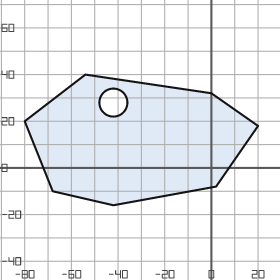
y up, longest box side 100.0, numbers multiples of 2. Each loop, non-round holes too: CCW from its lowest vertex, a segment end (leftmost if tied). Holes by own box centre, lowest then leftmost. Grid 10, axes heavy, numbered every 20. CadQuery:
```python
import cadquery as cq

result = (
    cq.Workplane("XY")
    .moveTo(-42.0, -16.0)
    .lineTo(2.0, -8.0)
    .lineTo(20.0, 18.0)
    .lineTo(0.0, 32.0)
    .lineTo(-54.0, 40.0)
    .lineTo(-80.0, 20.0)
    .lineTo(-68.0, -10.0)
    .close()
    .moveTo(-42.0, 28.0)
    .circle(6.0)
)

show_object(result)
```